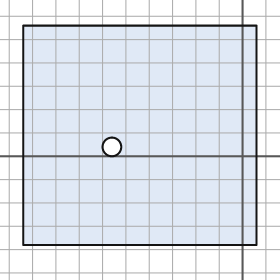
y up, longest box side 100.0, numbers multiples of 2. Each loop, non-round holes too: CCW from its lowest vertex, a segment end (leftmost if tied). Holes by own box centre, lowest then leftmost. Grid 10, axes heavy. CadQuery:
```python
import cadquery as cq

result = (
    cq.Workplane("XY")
    .moveTo(-94.0, -38.0)
    .lineTo(6.0, -38.0)
    .lineTo(6.0, 56.0)
    .lineTo(-94.0, 56.0)
    .close()
    .moveTo(-56.0, 4.0)
    .circle(4.0)
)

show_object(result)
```